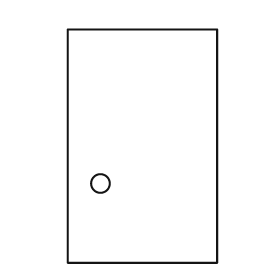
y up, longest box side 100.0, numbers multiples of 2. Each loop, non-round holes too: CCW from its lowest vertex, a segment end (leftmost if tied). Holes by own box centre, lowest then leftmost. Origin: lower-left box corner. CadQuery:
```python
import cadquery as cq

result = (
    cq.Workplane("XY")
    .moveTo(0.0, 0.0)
    .lineTo(64.0, 0.0)
    .lineTo(64.0, 100.0)
    .lineTo(0.0, 100.0)
    .close()
    .moveTo(14.0, 34.0)
    .circle(4.0)
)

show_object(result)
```